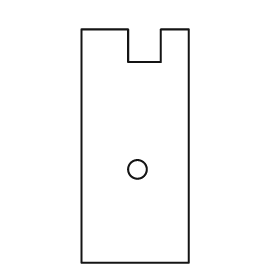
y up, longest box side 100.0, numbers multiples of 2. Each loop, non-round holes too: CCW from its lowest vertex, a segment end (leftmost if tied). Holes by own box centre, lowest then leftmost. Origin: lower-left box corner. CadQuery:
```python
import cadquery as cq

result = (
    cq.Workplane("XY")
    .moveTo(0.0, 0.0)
    .lineTo(46.0, 0.0)
    .lineTo(46.0, 100.0)
    .lineTo(34.0, 100.0)
    .lineTo(34.0, 86.0)
    .lineTo(20.0, 86.0)
    .lineTo(20.0, 100.0)
    .lineTo(0.0, 100.0)
    .close()
    .moveTo(24.0, 40.0)
    .circle(4.0)
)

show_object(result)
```